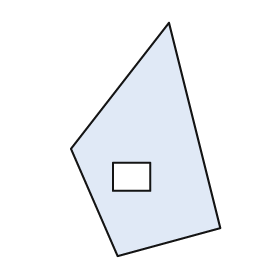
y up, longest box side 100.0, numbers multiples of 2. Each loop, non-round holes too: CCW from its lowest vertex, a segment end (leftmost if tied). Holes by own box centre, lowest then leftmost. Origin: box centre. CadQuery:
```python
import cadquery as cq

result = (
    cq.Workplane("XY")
    .moveTo(-12.0, -50.0)
    .lineTo(32.0, -38.0)
    .lineTo(10.0, 50.0)
    .lineTo(-32.0, -4.0)
    .close()
    .moveTo(-14.0, -22.0)
    .lineTo(2.0, -22.0)
    .lineTo(2.0, -10.0)
    .lineTo(-14.0, -10.0)
    .close()
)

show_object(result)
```